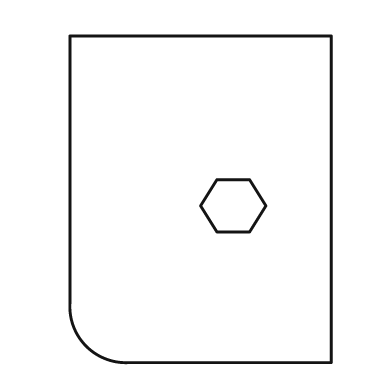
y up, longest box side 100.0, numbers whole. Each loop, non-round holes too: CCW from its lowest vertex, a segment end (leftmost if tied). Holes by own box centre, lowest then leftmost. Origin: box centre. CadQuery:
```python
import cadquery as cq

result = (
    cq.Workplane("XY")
    .moveTo(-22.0, -50.0)
    .lineTo(40.0, -50.0)
    .lineTo(40.0, 50.0)
    .lineTo(-40.0, 50.0)
    .lineTo(-40.0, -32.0)
    .threePointArc((-35.0, -45.0), (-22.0, -50.0))
    .close()
    .moveTo(5.0, -10.0)
    .lineTo(15.0, -10.0)
    .lineTo(20.0, -2.0)
    .lineTo(15.0, 6.0)
    .lineTo(5.0, 6.0)
    .lineTo(0.0, -2.0)
    .close()
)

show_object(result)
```